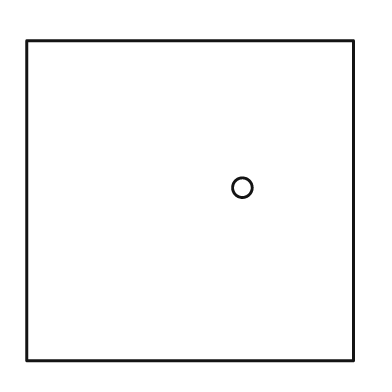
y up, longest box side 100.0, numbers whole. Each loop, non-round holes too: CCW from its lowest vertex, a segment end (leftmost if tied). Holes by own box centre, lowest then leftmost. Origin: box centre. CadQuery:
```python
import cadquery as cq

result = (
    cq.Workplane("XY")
    .moveTo(-50.0, -49.0)
    .lineTo(50.0, -49.0)
    .lineTo(50.0, 49.0)
    .lineTo(-50.0, 49.0)
    .close()
    .moveTo(16.0, 4.0)
    .circle(3.0)
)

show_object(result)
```